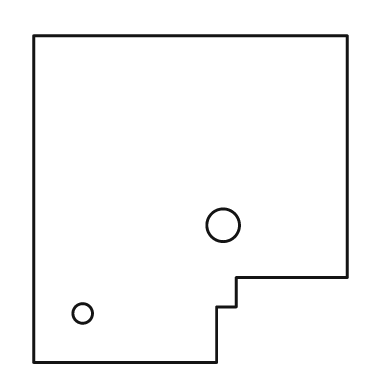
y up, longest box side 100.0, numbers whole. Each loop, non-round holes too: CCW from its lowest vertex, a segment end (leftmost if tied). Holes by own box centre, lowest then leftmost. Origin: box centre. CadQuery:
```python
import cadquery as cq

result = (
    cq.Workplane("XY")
    .moveTo(-48.0, -50.0)
    .lineTo(8.0, -50.0)
    .lineTo(8.0, -33.0)
    .lineTo(14.0, -33.0)
    .lineTo(14.0, -24.0)
    .lineTo(48.0, -24.0)
    .lineTo(48.0, 50.0)
    .lineTo(-48.0, 50.0)
    .close()
    .moveTo(-33.0, -35.0)
    .circle(3.0)
    .moveTo(10.0, -8.0)
    .circle(5.0)
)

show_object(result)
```